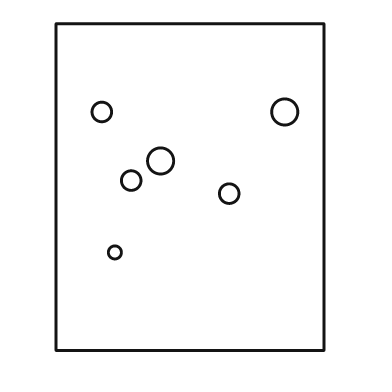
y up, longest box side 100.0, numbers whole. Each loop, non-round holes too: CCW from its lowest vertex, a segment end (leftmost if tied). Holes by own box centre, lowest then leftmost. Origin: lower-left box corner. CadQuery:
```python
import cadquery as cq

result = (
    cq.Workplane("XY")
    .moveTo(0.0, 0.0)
    .lineTo(82.0, 0.0)
    .lineTo(82.0, 100.0)
    .lineTo(0.0, 100.0)
    .close()
    .moveTo(18.0, 30.0)
    .circle(2.0)
    .moveTo(53.0, 48.0)
    .circle(3.0)
    .moveTo(23.0, 52.0)
    .circle(3.0)
    .moveTo(32.0, 58.0)
    .circle(4.0)
    .moveTo(14.0, 73.0)
    .circle(3.0)
    .moveTo(70.0, 73.0)
    .circle(4.0)
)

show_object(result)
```